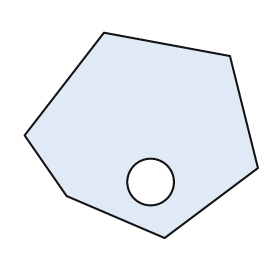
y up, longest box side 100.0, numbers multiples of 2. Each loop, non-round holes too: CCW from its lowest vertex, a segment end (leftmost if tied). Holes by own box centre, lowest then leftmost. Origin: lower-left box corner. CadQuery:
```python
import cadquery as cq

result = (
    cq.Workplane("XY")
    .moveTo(60.0, 0.0)
    .lineTo(100.0, 30.0)
    .lineTo(88.0, 78.0)
    .lineTo(34.0, 88.0)
    .lineTo(0.0, 44.0)
    .lineTo(18.0, 18.0)
    .close()
    .moveTo(54.0, 24.0)
    .circle(10.0)
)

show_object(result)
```